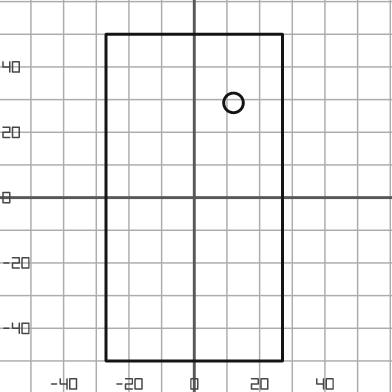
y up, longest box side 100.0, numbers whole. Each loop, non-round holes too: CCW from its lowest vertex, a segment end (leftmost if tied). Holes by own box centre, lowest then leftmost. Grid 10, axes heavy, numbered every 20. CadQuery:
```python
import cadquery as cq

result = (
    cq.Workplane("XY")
    .moveTo(-27.0, -50.0)
    .lineTo(27.0, -50.0)
    .lineTo(27.0, 50.0)
    .lineTo(-27.0, 50.0)
    .close()
    .moveTo(12.0, 29.0)
    .circle(3.0)
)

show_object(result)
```